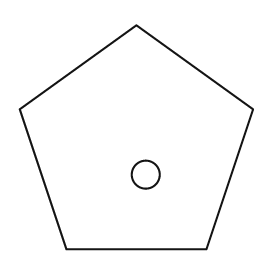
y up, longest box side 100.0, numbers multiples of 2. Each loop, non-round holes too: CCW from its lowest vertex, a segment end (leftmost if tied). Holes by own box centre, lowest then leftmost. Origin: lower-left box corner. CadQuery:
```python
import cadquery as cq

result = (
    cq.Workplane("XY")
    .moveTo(20.0, 0.0)
    .lineTo(80.0, 0.0)
    .lineTo(100.0, 60.0)
    .lineTo(50.0, 96.0)
    .lineTo(0.0, 60.0)
    .close()
    .moveTo(54.0, 32.0)
    .circle(6.0)
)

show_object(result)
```